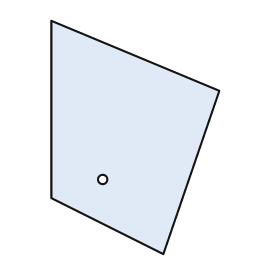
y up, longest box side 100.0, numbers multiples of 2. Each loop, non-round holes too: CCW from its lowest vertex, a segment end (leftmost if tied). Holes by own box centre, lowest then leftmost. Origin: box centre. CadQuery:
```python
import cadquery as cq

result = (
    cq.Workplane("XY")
    .moveTo(12.0, -50.0)
    .lineTo(36.0, 20.0)
    .lineTo(-36.0, 50.0)
    .lineTo(-36.0, -26.0)
    .close()
    .moveTo(-14.0, -18.0)
    .circle(2.0)
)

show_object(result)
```